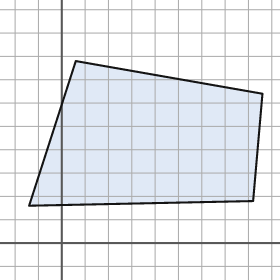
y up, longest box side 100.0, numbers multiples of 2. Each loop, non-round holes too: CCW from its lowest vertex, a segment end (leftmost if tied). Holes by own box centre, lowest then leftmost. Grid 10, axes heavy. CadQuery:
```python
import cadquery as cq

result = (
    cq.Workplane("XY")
    .moveTo(-14.0, 16.0)
    .lineTo(82.0, 18.0)
    .lineTo(86.0, 64.0)
    .lineTo(6.0, 78.0)
    .close()
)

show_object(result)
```